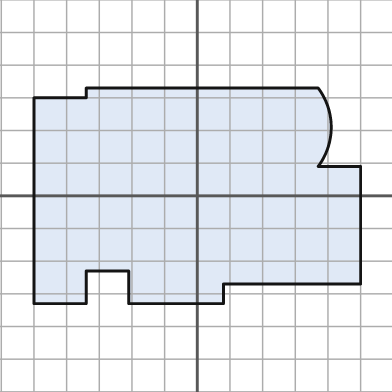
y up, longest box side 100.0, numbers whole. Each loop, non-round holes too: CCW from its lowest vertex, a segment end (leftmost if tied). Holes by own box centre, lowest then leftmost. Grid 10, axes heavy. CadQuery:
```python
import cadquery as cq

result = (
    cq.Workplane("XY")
    .moveTo(-50.0, -33.0)
    .lineTo(-34.0, -33.0)
    .lineTo(-34.0, -23.0)
    .lineTo(-21.0, -23.0)
    .lineTo(-21.0, -33.0)
    .lineTo(8.0, -33.0)
    .lineTo(8.0, -27.0)
    .lineTo(50.0, -27.0)
    .lineTo(50.0, 9.0)
    .lineTo(37.0, 9.0)
    .threePointArc((41.0, 21.0), (37.0, 33.0))
    .lineTo(-34.0, 33.0)
    .lineTo(-34.0, 30.0)
    .lineTo(-50.0, 30.0)
    .close()
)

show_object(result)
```